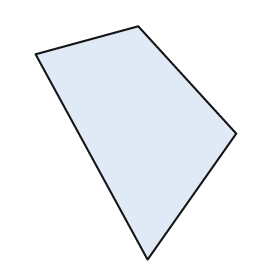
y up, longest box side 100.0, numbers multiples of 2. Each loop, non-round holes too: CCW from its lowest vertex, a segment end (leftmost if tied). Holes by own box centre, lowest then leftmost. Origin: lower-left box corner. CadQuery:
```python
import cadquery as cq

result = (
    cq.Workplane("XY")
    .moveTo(48.0, 0.0)
    .lineTo(86.0, 54.0)
    .lineTo(44.0, 100.0)
    .lineTo(0.0, 88.0)
    .close()
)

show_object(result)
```